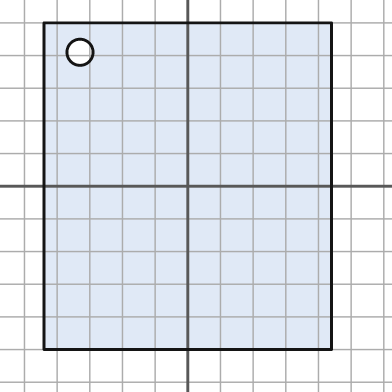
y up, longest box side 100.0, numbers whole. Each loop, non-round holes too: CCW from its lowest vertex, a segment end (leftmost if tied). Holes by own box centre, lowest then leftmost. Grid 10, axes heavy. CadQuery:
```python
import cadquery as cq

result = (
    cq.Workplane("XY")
    .moveTo(-44.0, -50.0)
    .lineTo(44.0, -50.0)
    .lineTo(44.0, 50.0)
    .lineTo(-44.0, 50.0)
    .close()
    .moveTo(-33.0, 41.0)
    .circle(4.0)
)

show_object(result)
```